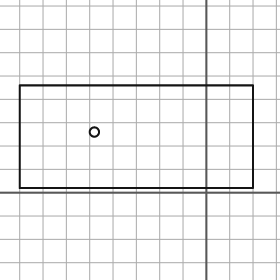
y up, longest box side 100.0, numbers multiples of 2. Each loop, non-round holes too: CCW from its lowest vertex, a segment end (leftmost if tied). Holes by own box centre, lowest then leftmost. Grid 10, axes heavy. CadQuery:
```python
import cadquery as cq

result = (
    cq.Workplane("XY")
    .moveTo(-80.0, 2.0)
    .lineTo(20.0, 2.0)
    .lineTo(20.0, 46.0)
    .lineTo(-80.0, 46.0)
    .close()
    .moveTo(-48.0, 26.0)
    .circle(2.0)
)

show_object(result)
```